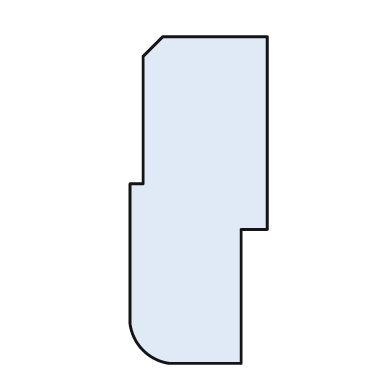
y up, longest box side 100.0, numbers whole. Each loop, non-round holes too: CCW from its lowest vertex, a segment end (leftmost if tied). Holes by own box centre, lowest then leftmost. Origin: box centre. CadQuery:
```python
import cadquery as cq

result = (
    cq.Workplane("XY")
    .moveTo(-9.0, -50.0)
    .lineTo(13.0, -50.0)
    .lineTo(13.0, -9.0)
    .lineTo(21.0, -9.0)
    .lineTo(21.0, 50.0)
    .lineTo(-11.0, 50.0)
    .lineTo(-17.0, 44.0)
    .lineTo(-17.0, 5.0)
    .lineTo(-21.0, 5.0)
    .lineTo(-21.0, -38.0)
    .threePointArc((-17.0, -46.0), (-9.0, -50.0))
    .close()
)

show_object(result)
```